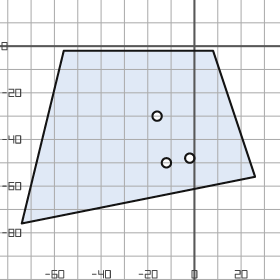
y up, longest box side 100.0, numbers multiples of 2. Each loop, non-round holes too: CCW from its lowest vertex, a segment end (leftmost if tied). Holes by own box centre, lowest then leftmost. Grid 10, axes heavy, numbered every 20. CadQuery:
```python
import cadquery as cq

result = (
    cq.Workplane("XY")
    .moveTo(-74.0, -76.0)
    .lineTo(26.0, -56.0)
    .lineTo(8.0, -2.0)
    .lineTo(-56.0, -2.0)
    .close()
    .moveTo(-12.0, -50.0)
    .circle(2.0)
    .moveTo(-2.0, -48.0)
    .circle(2.0)
    .moveTo(-16.0, -30.0)
    .circle(2.0)
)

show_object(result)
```